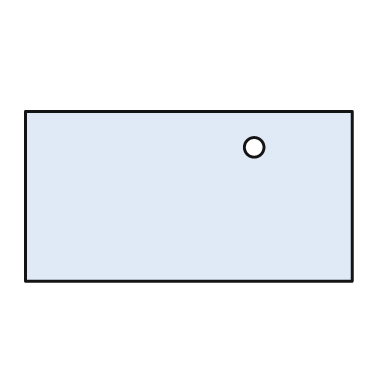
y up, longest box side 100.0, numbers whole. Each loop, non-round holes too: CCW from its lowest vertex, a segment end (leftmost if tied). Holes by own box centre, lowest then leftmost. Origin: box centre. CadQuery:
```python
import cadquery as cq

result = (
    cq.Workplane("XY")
    .moveTo(-50.0, -26.0)
    .lineTo(50.0, -26.0)
    .lineTo(50.0, 26.0)
    .lineTo(-50.0, 26.0)
    .close()
    .moveTo(20.0, 15.0)
    .circle(3.0)
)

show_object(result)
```